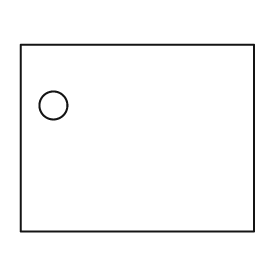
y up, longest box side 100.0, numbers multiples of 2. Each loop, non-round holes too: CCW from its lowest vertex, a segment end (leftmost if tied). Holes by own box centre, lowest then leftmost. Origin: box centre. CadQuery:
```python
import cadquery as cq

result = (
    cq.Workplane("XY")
    .moveTo(-50.0, -40.0)
    .lineTo(50.0, -40.0)
    .lineTo(50.0, 40.0)
    .lineTo(-50.0, 40.0)
    .close()
    .moveTo(-36.0, 14.0)
    .circle(6.0)
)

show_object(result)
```